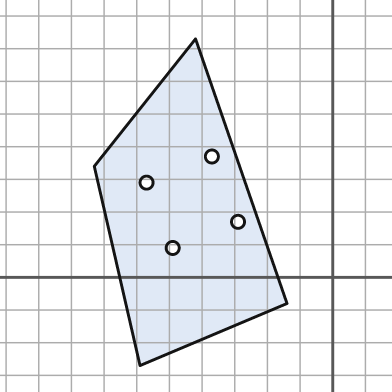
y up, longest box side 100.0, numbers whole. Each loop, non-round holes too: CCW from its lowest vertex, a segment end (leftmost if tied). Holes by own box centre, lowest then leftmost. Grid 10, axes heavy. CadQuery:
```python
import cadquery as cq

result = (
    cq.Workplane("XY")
    .moveTo(-59.0, -27.0)
    .lineTo(-14.0, -8.0)
    .lineTo(-42.0, 73.0)
    .lineTo(-73.0, 34.0)
    .close()
    .moveTo(-49.0, 9.0)
    .circle(2.0)
    .moveTo(-29.0, 17.0)
    .circle(2.0)
    .moveTo(-57.0, 29.0)
    .circle(2.0)
    .moveTo(-37.0, 37.0)
    .circle(2.0)
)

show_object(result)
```